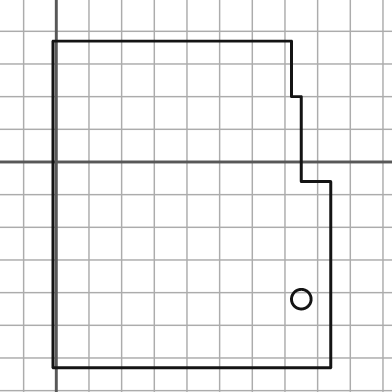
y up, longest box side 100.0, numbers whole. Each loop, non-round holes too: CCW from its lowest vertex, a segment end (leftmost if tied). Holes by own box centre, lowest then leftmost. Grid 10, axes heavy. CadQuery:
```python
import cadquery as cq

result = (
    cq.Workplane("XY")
    .moveTo(-1.0, -63.0)
    .lineTo(84.0, -63.0)
    .lineTo(84.0, -6.0)
    .lineTo(75.0, -6.0)
    .lineTo(75.0, 20.0)
    .lineTo(72.0, 20.0)
    .lineTo(72.0, 37.0)
    .lineTo(-1.0, 37.0)
    .close()
    .moveTo(75.0, -42.0)
    .circle(3.0)
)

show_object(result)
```